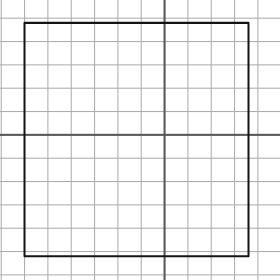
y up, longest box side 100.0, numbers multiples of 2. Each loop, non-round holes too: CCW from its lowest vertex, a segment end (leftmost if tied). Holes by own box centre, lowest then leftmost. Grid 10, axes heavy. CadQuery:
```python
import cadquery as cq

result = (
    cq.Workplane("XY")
    .moveTo(-60.0, -52.0)
    .lineTo(36.0, -52.0)
    .lineTo(36.0, 48.0)
    .lineTo(-60.0, 48.0)
    .close()
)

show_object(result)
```